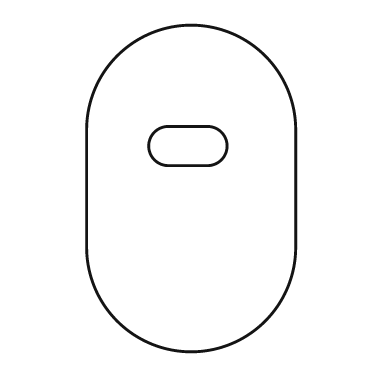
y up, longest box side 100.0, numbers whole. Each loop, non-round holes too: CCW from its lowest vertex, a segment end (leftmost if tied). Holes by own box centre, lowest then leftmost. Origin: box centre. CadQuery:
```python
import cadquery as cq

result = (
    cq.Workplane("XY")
    .moveTo(-32.0, -18.0)
    .threePointArc((0.0, -50.0), (32.0, -18.0))
    .lineTo(32.0, 18.0)
    .threePointArc((0.0, 50.0), (-32.0, 18.0))
    .close()
    .moveTo(-7.0, 7.0)
    .lineTo(5.0, 7.0)
    .threePointArc((11.0, 13.0), (5.0, 19.0))
    .lineTo(-7.0, 19.0)
    .threePointArc((-13.0, 13.0), (-7.0, 7.0))
    .close()
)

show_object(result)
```